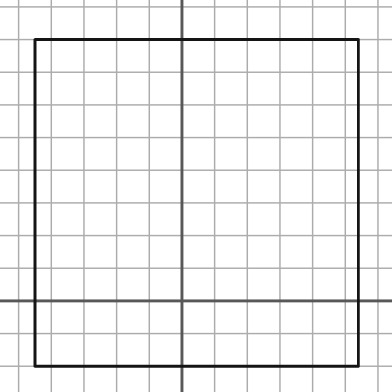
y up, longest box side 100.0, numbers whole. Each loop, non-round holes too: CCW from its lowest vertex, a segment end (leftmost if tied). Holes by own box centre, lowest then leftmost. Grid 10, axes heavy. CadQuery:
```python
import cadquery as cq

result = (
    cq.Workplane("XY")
    .moveTo(-45.0, -20.0)
    .lineTo(54.0, -20.0)
    .lineTo(54.0, 80.0)
    .lineTo(-45.0, 80.0)
    .close()
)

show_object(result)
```